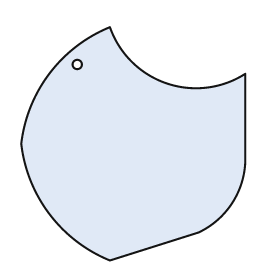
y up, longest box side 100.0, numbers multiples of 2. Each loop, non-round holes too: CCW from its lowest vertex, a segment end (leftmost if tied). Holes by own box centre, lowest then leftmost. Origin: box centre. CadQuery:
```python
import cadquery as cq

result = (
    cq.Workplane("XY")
    .moveTo(-10.0, -50.0)
    .lineTo(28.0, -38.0)
    .threePointArc((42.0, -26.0), (48.0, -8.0))
    .lineTo(48.0, 30.0)
    .threePointArc((14.0, 26.0), (-10.0, 50.0))
    .threePointArc((-36.0, 30.0), (-48.0, 0.0))
    .threePointArc((-36.0, -30.0), (-10.0, -50.0))
    .close()
    .moveTo(-24.0, 34.0)
    .circle(2.0)
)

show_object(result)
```